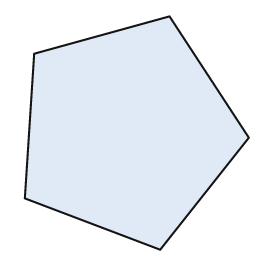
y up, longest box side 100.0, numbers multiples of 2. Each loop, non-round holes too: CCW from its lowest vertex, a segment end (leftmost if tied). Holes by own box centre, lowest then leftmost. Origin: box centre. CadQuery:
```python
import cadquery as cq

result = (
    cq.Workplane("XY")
    .moveTo(10.0, -50.0)
    .lineTo(48.0, -2.0)
    .lineTo(14.0, 50.0)
    .lineTo(-44.0, 34.0)
    .lineTo(-48.0, -28.0)
    .close()
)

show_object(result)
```